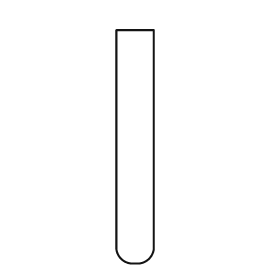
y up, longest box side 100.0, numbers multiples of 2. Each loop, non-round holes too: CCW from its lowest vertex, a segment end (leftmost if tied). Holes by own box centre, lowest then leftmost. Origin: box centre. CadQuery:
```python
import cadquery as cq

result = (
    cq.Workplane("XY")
    .moveTo(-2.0, -50.0)
    .lineTo(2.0, -50.0)
    .threePointArc((6.0, -48.0), (8.0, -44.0))
    .lineTo(8.0, 50.0)
    .lineTo(-8.0, 50.0)
    .lineTo(-8.0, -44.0)
    .threePointArc((-6.0, -48.0), (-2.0, -50.0))
    .close()
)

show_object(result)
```